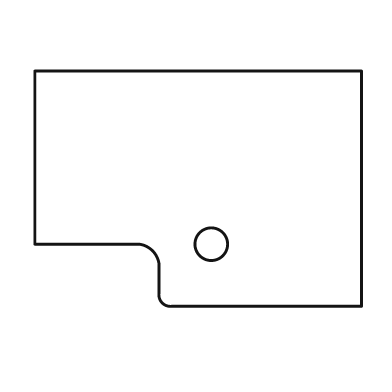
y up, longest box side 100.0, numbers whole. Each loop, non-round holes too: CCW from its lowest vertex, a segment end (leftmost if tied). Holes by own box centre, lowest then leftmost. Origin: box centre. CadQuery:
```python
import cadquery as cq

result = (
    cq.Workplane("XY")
    .moveTo(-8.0, -36.0)
    .lineTo(50.0, -36.0)
    .lineTo(50.0, 36.0)
    .lineTo(-50.0, 36.0)
    .lineTo(-50.0, -17.0)
    .lineTo(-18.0, -17.0)
    .threePointArc((-14.0, -19.0), (-12.0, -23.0))
    .lineTo(-12.0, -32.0)
    .threePointArc((-11.0, -35.0), (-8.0, -36.0))
    .close()
    .moveTo(4.0, -17.0)
    .circle(5.0)
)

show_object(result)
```